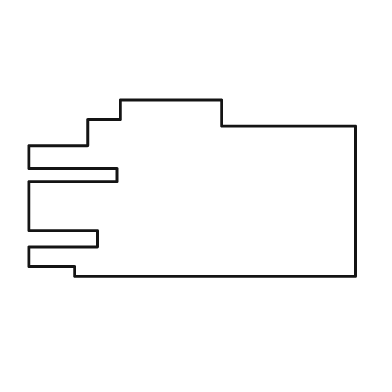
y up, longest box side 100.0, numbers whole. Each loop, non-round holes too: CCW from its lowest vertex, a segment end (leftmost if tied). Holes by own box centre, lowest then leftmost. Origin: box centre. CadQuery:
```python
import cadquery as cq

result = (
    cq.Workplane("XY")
    .moveTo(-36.0, -27.0)
    .lineTo(50.0, -27.0)
    .lineTo(50.0, 19.0)
    .lineTo(9.0, 19.0)
    .lineTo(9.0, 27.0)
    .lineTo(-22.0, 27.0)
    .lineTo(-22.0, 21.0)
    .lineTo(-32.0, 21.0)
    .lineTo(-32.0, 13.0)
    .lineTo(-50.0, 13.0)
    .lineTo(-50.0, 6.0)
    .lineTo(-23.0, 6.0)
    .lineTo(-23.0, 2.0)
    .lineTo(-50.0, 2.0)
    .lineTo(-50.0, -13.0)
    .lineTo(-29.0, -13.0)
    .lineTo(-29.0, -18.0)
    .lineTo(-50.0, -18.0)
    .lineTo(-50.0, -24.0)
    .lineTo(-36.0, -24.0)
    .close()
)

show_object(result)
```